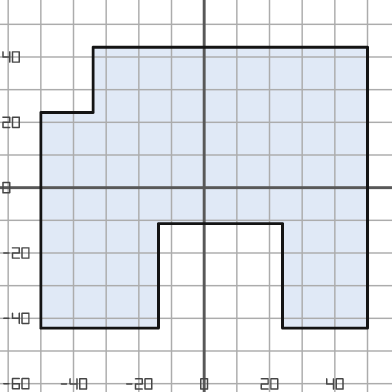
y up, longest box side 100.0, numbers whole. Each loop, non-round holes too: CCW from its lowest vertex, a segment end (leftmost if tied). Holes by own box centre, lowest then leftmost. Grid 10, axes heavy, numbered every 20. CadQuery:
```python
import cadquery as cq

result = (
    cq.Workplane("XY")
    .moveTo(-50.0, -43.0)
    .lineTo(-14.0, -43.0)
    .lineTo(-14.0, -11.0)
    .lineTo(24.0, -11.0)
    .lineTo(24.0, -43.0)
    .lineTo(50.0, -43.0)
    .lineTo(50.0, 43.0)
    .lineTo(-34.0, 43.0)
    .lineTo(-34.0, 23.0)
    .lineTo(-50.0, 23.0)
    .close()
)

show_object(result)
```